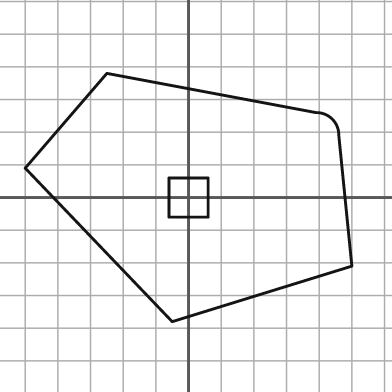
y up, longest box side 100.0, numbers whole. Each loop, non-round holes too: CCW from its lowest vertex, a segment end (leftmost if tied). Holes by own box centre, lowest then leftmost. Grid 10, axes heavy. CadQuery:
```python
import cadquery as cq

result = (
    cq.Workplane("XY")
    .moveTo(-5.0, -38.0)
    .lineTo(50.0, -21.0)
    .lineTo(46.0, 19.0)
    .threePointArc((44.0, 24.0), (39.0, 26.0))
    .lineTo(-25.0, 38.0)
    .lineTo(-50.0, 9.0)
    .close()
    .moveTo(-6.0, -6.0)
    .lineTo(6.0, -6.0)
    .lineTo(6.0, 6.0)
    .lineTo(-6.0, 6.0)
    .close()
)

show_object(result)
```